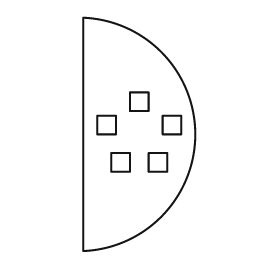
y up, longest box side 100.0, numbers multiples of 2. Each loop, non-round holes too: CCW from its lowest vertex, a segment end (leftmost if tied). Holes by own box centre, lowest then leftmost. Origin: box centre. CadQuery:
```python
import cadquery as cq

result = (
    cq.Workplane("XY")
    .moveTo(-24.0, -50.0)
    .threePointArc((24.0, 0.0), (-24.0, 50.0))
    .close()
    .moveTo(-12.0, -16.0)
    .lineTo(-4.0, -16.0)
    .lineTo(-4.0, -8.0)
    .lineTo(-12.0, -8.0)
    .close()
    .moveTo(4.0, -16.0)
    .lineTo(12.0, -16.0)
    .lineTo(12.0, -8.0)
    .lineTo(4.0, -8.0)
    .close()
    .moveTo(-18.0, 0.0)
    .lineTo(-10.0, 0.0)
    .lineTo(-10.0, 8.0)
    .lineTo(-18.0, 8.0)
    .close()
    .moveTo(10.0, 0.0)
    .lineTo(18.0, 0.0)
    .lineTo(18.0, 8.0)
    .lineTo(10.0, 8.0)
    .close()
    .moveTo(-4.0, 10.0)
    .lineTo(4.0, 10.0)
    .lineTo(4.0, 18.0)
    .lineTo(-4.0, 18.0)
    .close()
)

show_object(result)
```